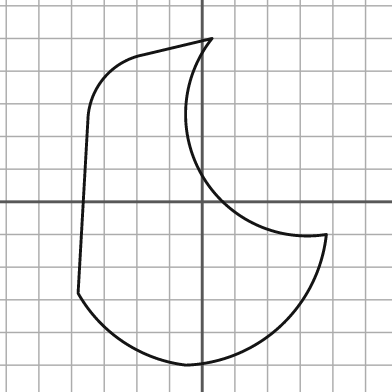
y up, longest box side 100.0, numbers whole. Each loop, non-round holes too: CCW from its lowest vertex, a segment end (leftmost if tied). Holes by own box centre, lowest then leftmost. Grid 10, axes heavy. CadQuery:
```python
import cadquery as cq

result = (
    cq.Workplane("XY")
    .moveTo(-5.0, -50.0)
    .threePointArc((24.0, -38.0), (38.0, -10.0))
    .threePointArc((0.0, 8.0), (3.0, 50.0))
    .lineTo(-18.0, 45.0)
    .threePointArc((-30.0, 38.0), (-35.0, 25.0))
    .lineTo(-38.0, -28.0)
    .threePointArc((-24.0, -43.0), (-5.0, -50.0))
    .close()
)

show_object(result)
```